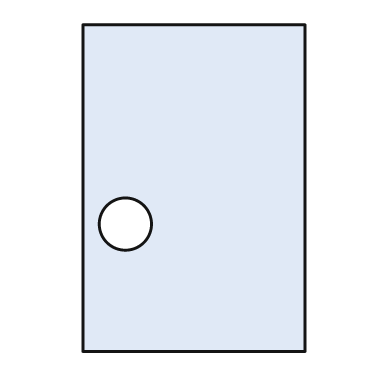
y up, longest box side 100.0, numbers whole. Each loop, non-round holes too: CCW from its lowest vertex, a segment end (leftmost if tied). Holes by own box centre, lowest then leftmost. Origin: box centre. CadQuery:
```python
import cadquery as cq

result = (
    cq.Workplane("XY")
    .moveTo(-34.0, -50.0)
    .lineTo(34.0, -50.0)
    .lineTo(34.0, 50.0)
    .lineTo(-34.0, 50.0)
    .close()
    .moveTo(-21.0, -11.0)
    .circle(8.0)
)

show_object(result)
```